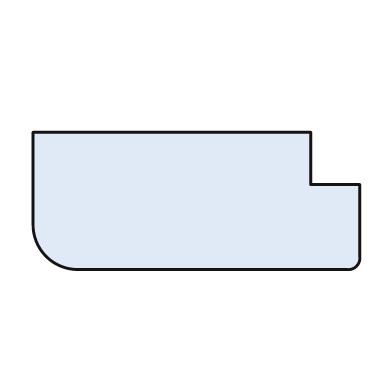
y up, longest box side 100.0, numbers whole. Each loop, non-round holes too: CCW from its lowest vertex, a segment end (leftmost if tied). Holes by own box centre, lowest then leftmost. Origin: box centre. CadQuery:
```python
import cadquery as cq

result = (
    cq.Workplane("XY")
    .moveTo(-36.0, -21.0)
    .lineTo(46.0, -21.0)
    .threePointArc((49.0, -20.0), (50.0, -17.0))
    .lineTo(50.0, 5.0)
    .lineTo(35.0, 5.0)
    .lineTo(35.0, 21.0)
    .lineTo(-50.0, 21.0)
    .lineTo(-50.0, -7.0)
    .threePointArc((-46.0, -17.0), (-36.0, -21.0))
    .close()
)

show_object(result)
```